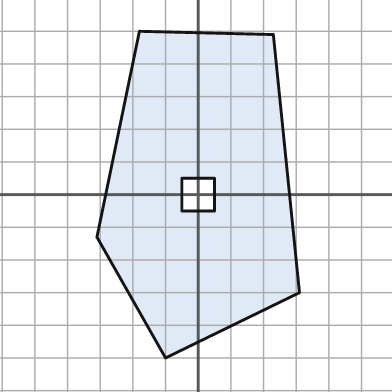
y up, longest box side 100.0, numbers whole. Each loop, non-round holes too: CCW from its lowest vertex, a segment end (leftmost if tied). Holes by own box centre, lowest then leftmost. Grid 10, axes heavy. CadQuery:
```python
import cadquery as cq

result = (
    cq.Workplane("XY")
    .moveTo(-10.0, -50.0)
    .lineTo(31.0, -30.0)
    .lineTo(23.0, 49.0)
    .lineTo(-18.0, 50.0)
    .lineTo(-31.0, -13.0)
    .close()
    .moveTo(-5.0, -5.0)
    .lineTo(5.0, -5.0)
    .lineTo(5.0, 5.0)
    .lineTo(-5.0, 5.0)
    .close()
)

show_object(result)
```